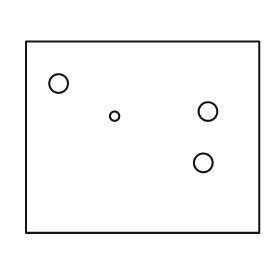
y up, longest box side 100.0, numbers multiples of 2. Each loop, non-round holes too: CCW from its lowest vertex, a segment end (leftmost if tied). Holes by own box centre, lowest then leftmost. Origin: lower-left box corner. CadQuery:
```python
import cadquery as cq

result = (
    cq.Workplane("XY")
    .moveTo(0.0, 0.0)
    .lineTo(100.0, 0.0)
    .lineTo(100.0, 82.0)
    .lineTo(0.0, 82.0)
    .close()
    .moveTo(76.0, 30.0)
    .circle(4.0)
    .moveTo(38.0, 50.0)
    .circle(2.0)
    .moveTo(78.0, 52.0)
    .circle(4.0)
    .moveTo(14.0, 64.0)
    .circle(4.0)
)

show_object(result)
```